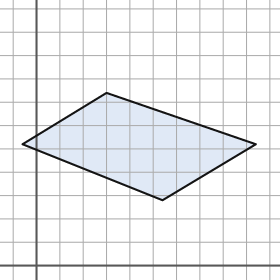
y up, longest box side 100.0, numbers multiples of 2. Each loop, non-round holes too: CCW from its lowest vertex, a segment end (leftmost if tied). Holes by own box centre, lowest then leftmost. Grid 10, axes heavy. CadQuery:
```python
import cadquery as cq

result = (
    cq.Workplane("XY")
    .moveTo(54.0, 28.0)
    .lineTo(94.0, 52.0)
    .lineTo(30.0, 74.0)
    .lineTo(-6.0, 52.0)
    .close()
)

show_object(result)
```